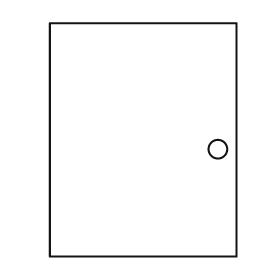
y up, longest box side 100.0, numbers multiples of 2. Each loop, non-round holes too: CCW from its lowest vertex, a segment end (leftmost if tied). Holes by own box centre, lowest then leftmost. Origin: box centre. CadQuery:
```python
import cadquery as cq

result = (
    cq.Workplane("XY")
    .moveTo(-40.0, -50.0)
    .lineTo(40.0, -50.0)
    .lineTo(40.0, 50.0)
    .lineTo(-40.0, 50.0)
    .close()
    .moveTo(32.0, -4.0)
    .circle(4.0)
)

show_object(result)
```